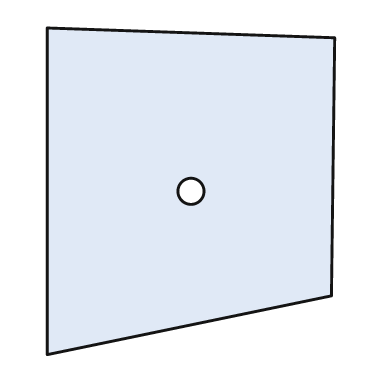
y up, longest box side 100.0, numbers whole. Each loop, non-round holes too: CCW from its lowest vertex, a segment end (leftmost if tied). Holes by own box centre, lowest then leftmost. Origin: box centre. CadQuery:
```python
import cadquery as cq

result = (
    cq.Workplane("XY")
    .moveTo(-44.0, -50.0)
    .lineTo(43.0, -32.0)
    .lineTo(44.0, 47.0)
    .lineTo(-44.0, 50.0)
    .close()
    .moveTo(0.0, 0.0)
    .circle(4.0)
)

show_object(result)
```